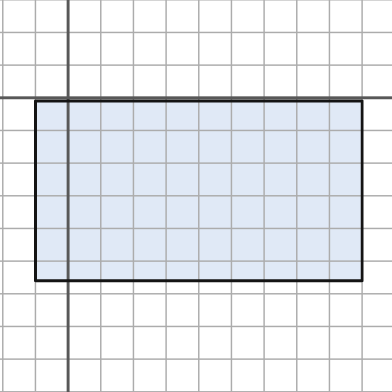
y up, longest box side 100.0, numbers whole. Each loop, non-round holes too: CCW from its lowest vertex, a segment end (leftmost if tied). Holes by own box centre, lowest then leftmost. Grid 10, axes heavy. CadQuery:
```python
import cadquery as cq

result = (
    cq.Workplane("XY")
    .moveTo(-10.0, -56.0)
    .lineTo(90.0, -56.0)
    .lineTo(90.0, -1.0)
    .lineTo(-10.0, -1.0)
    .close()
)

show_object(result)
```